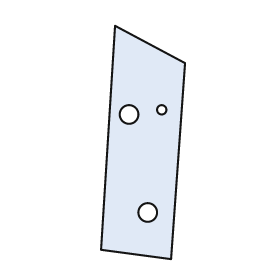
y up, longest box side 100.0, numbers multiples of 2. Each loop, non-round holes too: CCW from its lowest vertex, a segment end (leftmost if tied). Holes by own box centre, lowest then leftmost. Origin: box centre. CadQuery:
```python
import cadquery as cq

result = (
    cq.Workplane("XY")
    .moveTo(12.0, -50.0)
    .lineTo(18.0, 34.0)
    .lineTo(-12.0, 50.0)
    .lineTo(-18.0, -46.0)
    .close()
    .moveTo(2.0, -30.0)
    .circle(4.0)
    .moveTo(-6.0, 12.0)
    .circle(4.0)
    .moveTo(8.0, 14.0)
    .circle(2.0)
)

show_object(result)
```